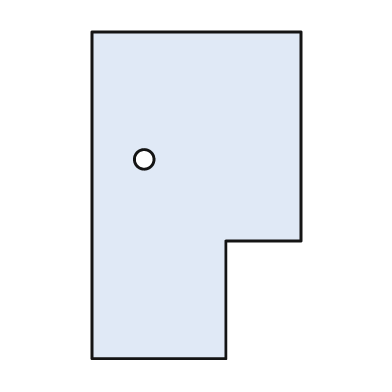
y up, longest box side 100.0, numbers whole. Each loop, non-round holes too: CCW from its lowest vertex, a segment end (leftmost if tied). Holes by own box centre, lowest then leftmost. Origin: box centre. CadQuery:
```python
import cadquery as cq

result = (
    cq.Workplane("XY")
    .moveTo(-32.0, -50.0)
    .lineTo(9.0, -50.0)
    .lineTo(9.0, -14.0)
    .lineTo(32.0, -14.0)
    .lineTo(32.0, 50.0)
    .lineTo(-32.0, 50.0)
    .close()
    .moveTo(-16.0, 11.0)
    .circle(3.0)
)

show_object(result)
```